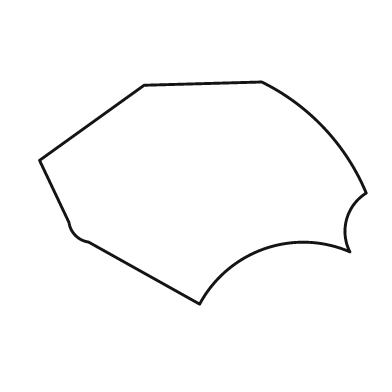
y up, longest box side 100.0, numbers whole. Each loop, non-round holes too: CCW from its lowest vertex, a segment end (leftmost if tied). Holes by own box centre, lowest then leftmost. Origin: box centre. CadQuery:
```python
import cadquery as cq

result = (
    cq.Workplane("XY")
    .moveTo(-1.0, -34.0)
    .threePointArc((19.0, -17.0), (45.0, -18.0))
    .threePointArc((44.0, -8.0), (50.0, 0.0))
    .threePointArc((37.0, 20.0), (18.0, 34.0))
    .lineTo(-18.0, 33.0)
    .lineTo(-50.0, 10.0)
    .lineTo(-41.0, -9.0)
    .threePointArc((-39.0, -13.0), (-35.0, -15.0))
    .close()
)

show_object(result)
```